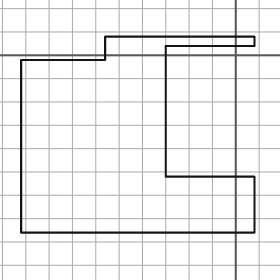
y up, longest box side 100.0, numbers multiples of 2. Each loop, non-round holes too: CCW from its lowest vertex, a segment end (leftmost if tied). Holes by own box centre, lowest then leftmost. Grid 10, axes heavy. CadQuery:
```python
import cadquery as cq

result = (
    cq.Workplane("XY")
    .moveTo(-92.0, -76.0)
    .lineTo(8.0, -76.0)
    .lineTo(8.0, -52.0)
    .lineTo(-30.0, -52.0)
    .lineTo(-30.0, 4.0)
    .lineTo(8.0, 4.0)
    .lineTo(8.0, 8.0)
    .lineTo(-56.0, 8.0)
    .lineTo(-56.0, -2.0)
    .lineTo(-92.0, -2.0)
    .close()
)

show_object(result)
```